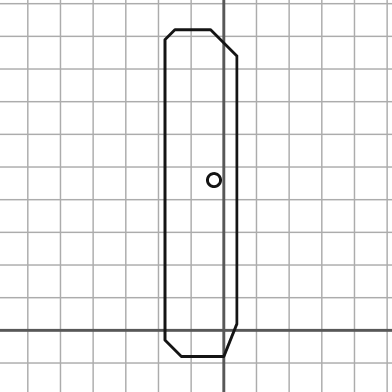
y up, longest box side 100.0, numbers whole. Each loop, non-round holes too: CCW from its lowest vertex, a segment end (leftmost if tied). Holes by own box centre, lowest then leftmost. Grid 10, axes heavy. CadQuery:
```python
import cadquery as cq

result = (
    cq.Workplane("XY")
    .moveTo(-13.0, -8.0)
    .lineTo(0.0, -8.0)
    .lineTo(4.0, 2.0)
    .lineTo(4.0, 84.0)
    .lineTo(-4.0, 92.0)
    .lineTo(-15.0, 92.0)
    .lineTo(-18.0, 89.0)
    .lineTo(-18.0, -3.0)
    .close()
    .moveTo(-3.0, 46.0)
    .circle(2.0)
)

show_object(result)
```